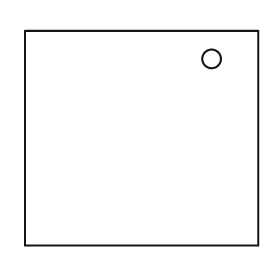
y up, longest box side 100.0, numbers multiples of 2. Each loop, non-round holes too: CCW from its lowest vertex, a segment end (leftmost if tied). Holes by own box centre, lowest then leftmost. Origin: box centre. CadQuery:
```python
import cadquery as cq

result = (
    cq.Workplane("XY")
    .moveTo(-50.0, -46.0)
    .lineTo(50.0, -46.0)
    .lineTo(50.0, 46.0)
    .lineTo(-50.0, 46.0)
    .close()
    .moveTo(30.0, 34.0)
    .circle(4.0)
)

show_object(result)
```